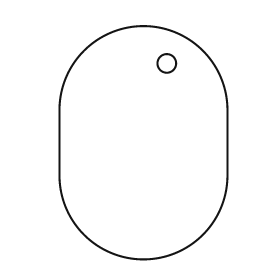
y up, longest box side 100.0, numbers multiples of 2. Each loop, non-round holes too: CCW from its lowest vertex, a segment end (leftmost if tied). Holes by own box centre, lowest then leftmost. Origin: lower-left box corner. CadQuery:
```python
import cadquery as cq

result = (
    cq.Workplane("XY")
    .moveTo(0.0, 36.0)
    .threePointArc((36.0, 0.0), (72.0, 36.0))
    .lineTo(72.0, 64.0)
    .threePointArc((36.0, 100.0), (0.0, 64.0))
    .close()
    .moveTo(46.0, 84.0)
    .circle(4.0)
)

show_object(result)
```